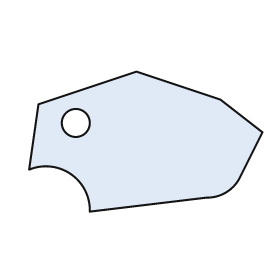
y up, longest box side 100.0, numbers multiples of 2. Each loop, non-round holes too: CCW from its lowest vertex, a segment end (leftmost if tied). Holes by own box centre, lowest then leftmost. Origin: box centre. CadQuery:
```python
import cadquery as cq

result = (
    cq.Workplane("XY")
    .moveTo(-24.0, -30.0)
    .lineTo(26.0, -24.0)
    .threePointArc((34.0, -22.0), (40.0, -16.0))
    .lineTo(50.0, 4.0)
    .lineTo(32.0, 18.0)
    .lineTo(-4.0, 30.0)
    .lineTo(-46.0, 16.0)
    .lineTo(-50.0, -12.0)
    .threePointArc((-32.0, -14.0), (-24.0, -30.0))
    .close()
    .moveTo(-30.0, 8.0)
    .circle(6.0)
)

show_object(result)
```